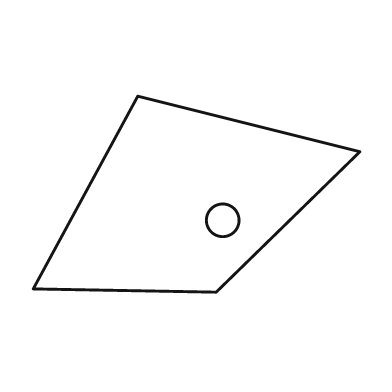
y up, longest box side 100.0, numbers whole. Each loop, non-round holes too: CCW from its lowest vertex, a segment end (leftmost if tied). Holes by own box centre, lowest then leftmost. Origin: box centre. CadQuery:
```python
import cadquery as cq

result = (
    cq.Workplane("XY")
    .moveTo(6.0, -30.0)
    .lineTo(50.0, 13.0)
    .lineTo(-18.0, 30.0)
    .lineTo(-50.0, -29.0)
    .close()
    .moveTo(8.0, -8.0)
    .circle(5.0)
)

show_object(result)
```